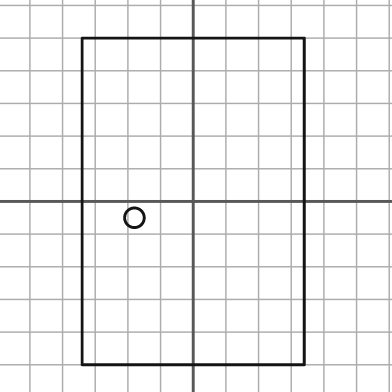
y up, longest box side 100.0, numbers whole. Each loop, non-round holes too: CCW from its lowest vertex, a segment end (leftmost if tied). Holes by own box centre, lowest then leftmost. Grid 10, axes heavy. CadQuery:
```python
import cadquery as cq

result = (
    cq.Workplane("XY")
    .moveTo(-34.0, -50.0)
    .lineTo(34.0, -50.0)
    .lineTo(34.0, 50.0)
    .lineTo(-34.0, 50.0)
    .close()
    .moveTo(-18.0, -5.0)
    .circle(3.0)
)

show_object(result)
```